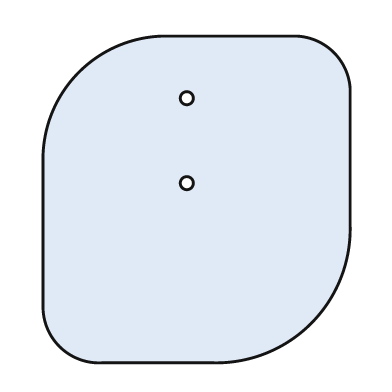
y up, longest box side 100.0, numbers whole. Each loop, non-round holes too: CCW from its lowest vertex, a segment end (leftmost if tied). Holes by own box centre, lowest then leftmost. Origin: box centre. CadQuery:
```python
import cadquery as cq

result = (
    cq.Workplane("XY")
    .moveTo(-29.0, -50.0)
    .lineTo(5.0, -50.0)
    .threePointArc((35.0, -38.0), (47.0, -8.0))
    .lineTo(47.0, 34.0)
    .threePointArc((42.0, 45.0), (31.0, 50.0))
    .lineTo(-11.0, 50.0)
    .threePointArc((-36.0, 39.0), (-47.0, 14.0))
    .lineTo(-47.0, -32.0)
    .threePointArc((-42.0, -45.0), (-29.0, -50.0))
    .close()
    .moveTo(-3.0, 5.0)
    .circle(2.0)
    .moveTo(-3.0, 31.0)
    .circle(2.0)
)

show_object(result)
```